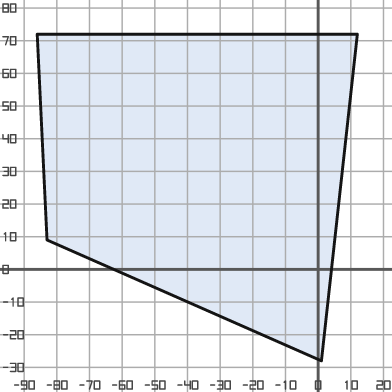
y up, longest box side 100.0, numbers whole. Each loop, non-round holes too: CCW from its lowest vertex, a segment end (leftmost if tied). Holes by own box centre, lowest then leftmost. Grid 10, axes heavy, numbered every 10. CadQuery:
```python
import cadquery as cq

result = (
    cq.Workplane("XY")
    .moveTo(1.0, -28.0)
    .lineTo(12.0, 72.0)
    .lineTo(-86.0, 72.0)
    .lineTo(-83.0, 9.0)
    .close()
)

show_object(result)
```